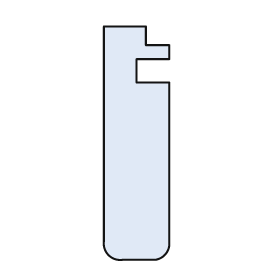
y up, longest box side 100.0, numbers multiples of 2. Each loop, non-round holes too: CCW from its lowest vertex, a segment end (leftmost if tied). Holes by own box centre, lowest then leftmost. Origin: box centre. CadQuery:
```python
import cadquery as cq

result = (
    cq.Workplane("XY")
    .moveTo(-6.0, -50.0)
    .lineTo(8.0, -50.0)
    .threePointArc((12.0, -48.0), (14.0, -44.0))
    .lineTo(14.0, 26.0)
    .lineTo(0.0, 26.0)
    .lineTo(0.0, 36.0)
    .lineTo(14.0, 36.0)
    .lineTo(14.0, 42.0)
    .lineTo(4.0, 42.0)
    .lineTo(4.0, 50.0)
    .lineTo(-14.0, 50.0)
    .lineTo(-14.0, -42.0)
    .threePointArc((-12.0, -48.0), (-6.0, -50.0))
    .close()
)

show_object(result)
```